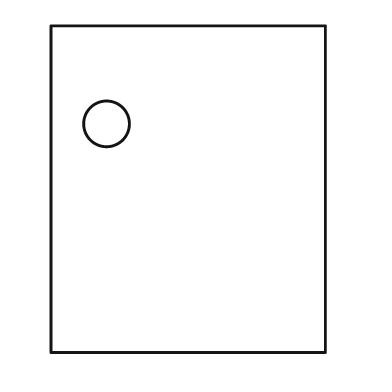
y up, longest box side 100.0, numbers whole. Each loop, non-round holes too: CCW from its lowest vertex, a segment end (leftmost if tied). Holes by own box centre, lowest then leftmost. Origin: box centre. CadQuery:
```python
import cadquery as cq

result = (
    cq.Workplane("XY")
    .moveTo(-42.0, -50.0)
    .lineTo(42.0, -50.0)
    .lineTo(42.0, 50.0)
    .lineTo(-42.0, 50.0)
    .close()
    .moveTo(-25.0, 20.0)
    .circle(7.0)
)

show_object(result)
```